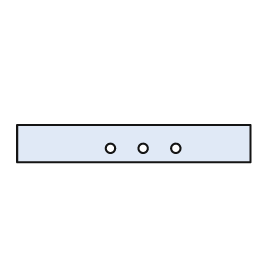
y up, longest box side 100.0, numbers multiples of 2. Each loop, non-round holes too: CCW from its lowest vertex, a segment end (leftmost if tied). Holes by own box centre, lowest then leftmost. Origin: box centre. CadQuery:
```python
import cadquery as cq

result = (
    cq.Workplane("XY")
    .moveTo(-50.0, -8.0)
    .lineTo(50.0, -8.0)
    .lineTo(50.0, 8.0)
    .lineTo(-50.0, 8.0)
    .close()
    .moveTo(-10.0, -2.0)
    .circle(2.0)
    .moveTo(4.0, -2.0)
    .circle(2.0)
    .moveTo(18.0, -2.0)
    .circle(2.0)
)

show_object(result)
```